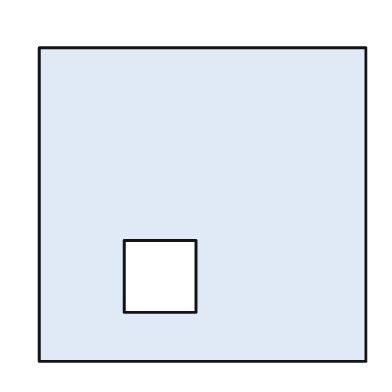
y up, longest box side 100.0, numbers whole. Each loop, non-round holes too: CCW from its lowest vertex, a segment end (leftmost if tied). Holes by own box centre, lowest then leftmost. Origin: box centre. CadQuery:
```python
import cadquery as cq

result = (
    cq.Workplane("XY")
    .moveTo(-50.0, -48.0)
    .lineTo(50.0, -48.0)
    .lineTo(50.0, 48.0)
    .lineTo(-50.0, 48.0)
    .close()
    .moveTo(-24.0, -33.0)
    .lineTo(-2.0, -33.0)
    .lineTo(-2.0, -11.0)
    .lineTo(-24.0, -11.0)
    .close()
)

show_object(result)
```